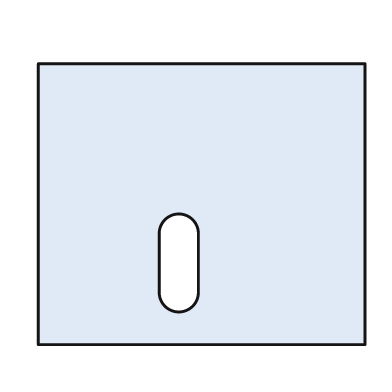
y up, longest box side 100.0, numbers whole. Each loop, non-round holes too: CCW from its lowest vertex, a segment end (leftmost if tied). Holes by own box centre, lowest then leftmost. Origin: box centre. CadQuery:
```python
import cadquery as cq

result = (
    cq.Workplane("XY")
    .moveTo(-50.0, -43.0)
    .lineTo(50.0, -43.0)
    .lineTo(50.0, 43.0)
    .lineTo(-50.0, 43.0)
    .close()
    .moveTo(-13.0, -27.0)
    .threePointArc((-7.0, -33.0), (-1.0, -27.0))
    .lineTo(-1.0, -9.0)
    .threePointArc((-7.0, -3.0), (-13.0, -9.0))
    .close()
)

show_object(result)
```